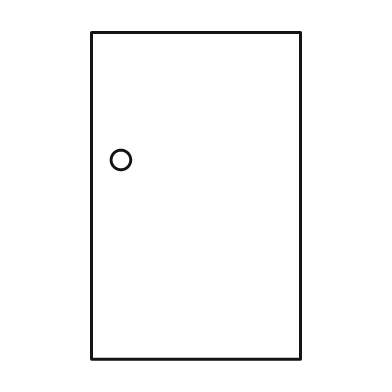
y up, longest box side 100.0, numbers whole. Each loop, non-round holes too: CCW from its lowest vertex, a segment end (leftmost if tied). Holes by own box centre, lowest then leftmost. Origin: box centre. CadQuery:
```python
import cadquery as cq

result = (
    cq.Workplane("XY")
    .moveTo(-32.0, -50.0)
    .lineTo(32.0, -50.0)
    .lineTo(32.0, 50.0)
    .lineTo(-32.0, 50.0)
    .close()
    .moveTo(-23.0, 11.0)
    .circle(3.0)
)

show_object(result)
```